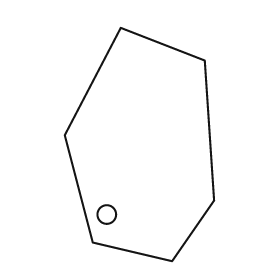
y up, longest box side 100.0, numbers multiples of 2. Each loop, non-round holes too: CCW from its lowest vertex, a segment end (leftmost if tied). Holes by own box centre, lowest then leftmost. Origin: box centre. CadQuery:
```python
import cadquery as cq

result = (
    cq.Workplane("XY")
    .moveTo(14.0, -50.0)
    .lineTo(32.0, -24.0)
    .lineTo(28.0, 36.0)
    .lineTo(-8.0, 50.0)
    .lineTo(-32.0, 4.0)
    .lineTo(-20.0, -42.0)
    .close()
    .moveTo(-14.0, -30.0)
    .circle(4.0)
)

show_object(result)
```